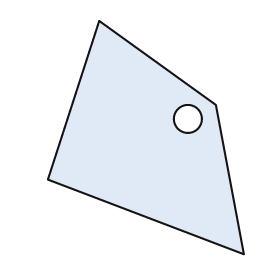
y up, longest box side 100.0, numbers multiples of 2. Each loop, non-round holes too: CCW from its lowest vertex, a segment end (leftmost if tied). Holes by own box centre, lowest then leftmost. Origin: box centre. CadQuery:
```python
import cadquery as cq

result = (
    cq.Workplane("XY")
    .moveTo(42.0, -50.0)
    .lineTo(30.0, 14.0)
    .lineTo(-20.0, 50.0)
    .lineTo(-42.0, -18.0)
    .close()
    .moveTo(18.0, 8.0)
    .circle(6.0)
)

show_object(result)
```